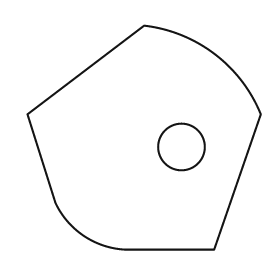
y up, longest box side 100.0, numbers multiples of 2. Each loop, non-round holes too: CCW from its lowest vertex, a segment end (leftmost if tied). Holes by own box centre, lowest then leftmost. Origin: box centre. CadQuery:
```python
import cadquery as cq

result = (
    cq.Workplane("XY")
    .moveTo(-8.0, -48.0)
    .lineTo(30.0, -48.0)
    .lineTo(50.0, 10.0)
    .threePointArc((30.0, 36.0), (0.0, 48.0))
    .lineTo(-50.0, 10.0)
    .lineTo(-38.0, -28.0)
    .threePointArc((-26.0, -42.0), (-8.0, -48.0))
    .close()
    .moveTo(16.0, -4.0)
    .circle(10.0)
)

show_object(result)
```